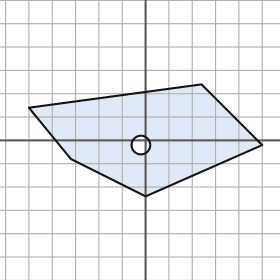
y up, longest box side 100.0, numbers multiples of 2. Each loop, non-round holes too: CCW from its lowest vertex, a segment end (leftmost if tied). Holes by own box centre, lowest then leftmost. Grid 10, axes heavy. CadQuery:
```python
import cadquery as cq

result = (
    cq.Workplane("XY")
    .moveTo(0.0, -24.0)
    .lineTo(50.0, -2.0)
    .lineTo(24.0, 24.0)
    .lineTo(-50.0, 14.0)
    .lineTo(-32.0, -8.0)
    .close()
    .moveTo(-2.0, -2.0)
    .circle(4.0)
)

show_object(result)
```